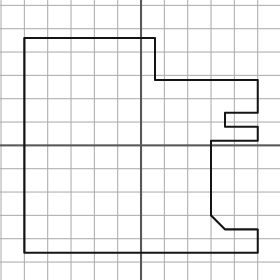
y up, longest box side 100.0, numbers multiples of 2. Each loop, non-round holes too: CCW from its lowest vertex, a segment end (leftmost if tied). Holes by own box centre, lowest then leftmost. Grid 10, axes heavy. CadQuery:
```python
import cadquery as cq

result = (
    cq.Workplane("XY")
    .moveTo(-50.0, -46.0)
    .lineTo(50.0, -46.0)
    .lineTo(50.0, -36.0)
    .lineTo(36.0, -36.0)
    .lineTo(30.0, -30.0)
    .lineTo(30.0, 2.0)
    .lineTo(50.0, 2.0)
    .lineTo(50.0, 8.0)
    .lineTo(36.0, 8.0)
    .lineTo(36.0, 14.0)
    .lineTo(50.0, 14.0)
    .lineTo(50.0, 28.0)
    .lineTo(6.0, 28.0)
    .lineTo(6.0, 46.0)
    .lineTo(-50.0, 46.0)
    .close()
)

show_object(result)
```